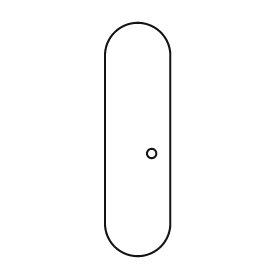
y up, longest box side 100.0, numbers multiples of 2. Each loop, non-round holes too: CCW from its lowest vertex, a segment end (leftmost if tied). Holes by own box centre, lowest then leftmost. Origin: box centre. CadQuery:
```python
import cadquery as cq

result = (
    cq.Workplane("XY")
    .moveTo(-14.0, -36.0)
    .threePointArc((0.0, -50.0), (14.0, -36.0))
    .lineTo(14.0, 36.0)
    .threePointArc((0.0, 50.0), (-14.0, 36.0))
    .close()
    .moveTo(6.0, -6.0)
    .circle(2.0)
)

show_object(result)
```